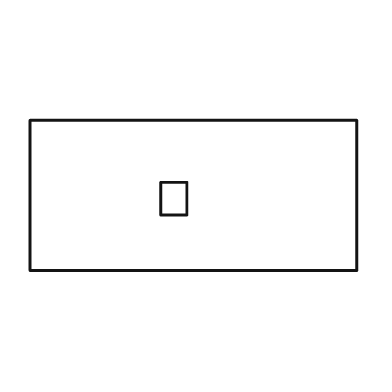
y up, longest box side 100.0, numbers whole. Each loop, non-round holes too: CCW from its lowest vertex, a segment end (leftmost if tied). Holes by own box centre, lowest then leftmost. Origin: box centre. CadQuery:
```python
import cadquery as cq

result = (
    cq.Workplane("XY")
    .moveTo(-50.0, -23.0)
    .lineTo(50.0, -23.0)
    .lineTo(50.0, 23.0)
    .lineTo(-50.0, 23.0)
    .close()
    .moveTo(-10.0, -6.0)
    .lineTo(-2.0, -6.0)
    .lineTo(-2.0, 4.0)
    .lineTo(-10.0, 4.0)
    .close()
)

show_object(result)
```